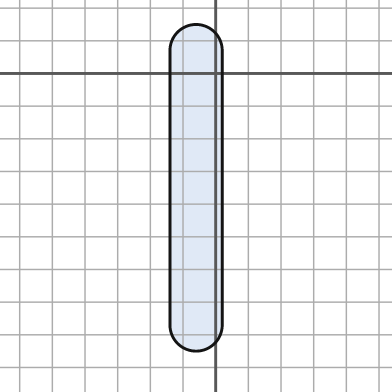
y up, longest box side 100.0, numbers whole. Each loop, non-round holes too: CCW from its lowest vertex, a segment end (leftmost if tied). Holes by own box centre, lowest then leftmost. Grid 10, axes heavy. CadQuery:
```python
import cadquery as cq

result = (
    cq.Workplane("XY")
    .moveTo(-14.0, -77.0)
    .threePointArc((-6.0, -85.0), (2.0, -77.0))
    .lineTo(2.0, 7.0)
    .threePointArc((-6.0, 15.0), (-14.0, 7.0))
    .close()
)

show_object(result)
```